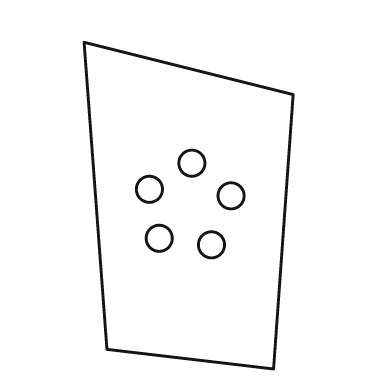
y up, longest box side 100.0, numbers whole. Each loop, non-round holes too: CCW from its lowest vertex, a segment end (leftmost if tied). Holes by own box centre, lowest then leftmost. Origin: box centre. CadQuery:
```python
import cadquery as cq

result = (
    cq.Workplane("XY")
    .moveTo(26.0, -50.0)
    .lineTo(32.0, 34.0)
    .lineTo(-32.0, 50.0)
    .lineTo(-25.0, -44.0)
    .close()
    .moveTo(7.0, -12.0)
    .circle(4.0)
    .moveTo(-9.0, -10.0)
    .circle(4.0)
    .moveTo(13.0, 3.0)
    .circle(4.0)
    .moveTo(-12.0, 5.0)
    .circle(4.0)
    .moveTo(1.0, 13.0)
    .circle(4.0)
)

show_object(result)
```